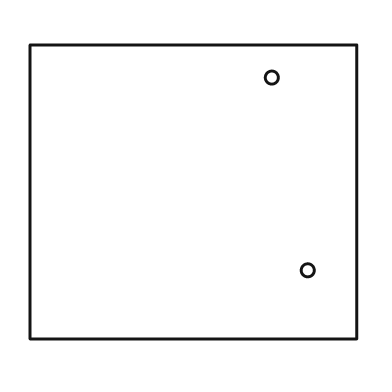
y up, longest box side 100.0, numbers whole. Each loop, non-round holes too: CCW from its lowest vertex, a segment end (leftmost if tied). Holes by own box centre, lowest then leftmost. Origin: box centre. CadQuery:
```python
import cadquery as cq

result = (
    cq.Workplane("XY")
    .moveTo(-50.0, -45.0)
    .lineTo(50.0, -45.0)
    .lineTo(50.0, 45.0)
    .lineTo(-50.0, 45.0)
    .close()
    .moveTo(35.0, -24.0)
    .circle(2.0)
    .moveTo(24.0, 35.0)
    .circle(2.0)
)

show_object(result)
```